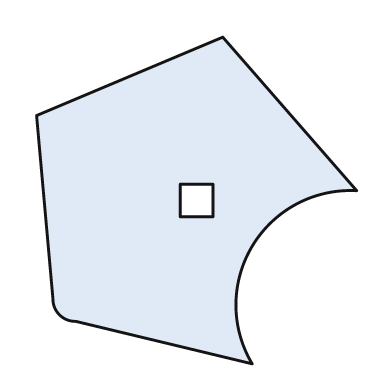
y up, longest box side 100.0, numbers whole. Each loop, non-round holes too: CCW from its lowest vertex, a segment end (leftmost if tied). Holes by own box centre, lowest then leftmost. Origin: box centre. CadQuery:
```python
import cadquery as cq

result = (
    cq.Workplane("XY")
    .moveTo(17.0, -50.0)
    .threePointArc((17.0, -14.0), (49.0, 3.0))
    .lineTo(8.0, 50.0)
    .lineTo(-49.0, 26.0)
    .lineTo(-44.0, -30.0)
    .threePointArc((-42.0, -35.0), (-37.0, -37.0))
    .close()
    .moveTo(-5.0, -5.0)
    .lineTo(5.0, -5.0)
    .lineTo(5.0, 5.0)
    .lineTo(-5.0, 5.0)
    .close()
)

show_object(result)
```